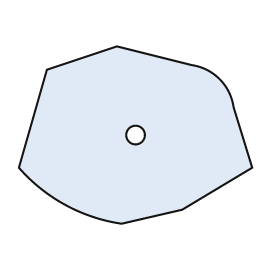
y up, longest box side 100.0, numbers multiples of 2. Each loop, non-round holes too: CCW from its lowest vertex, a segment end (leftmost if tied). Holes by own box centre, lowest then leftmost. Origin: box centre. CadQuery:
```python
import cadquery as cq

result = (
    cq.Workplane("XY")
    .moveTo(-6.0, -38.0)
    .lineTo(20.0, -32.0)
    .lineTo(50.0, -14.0)
    .lineTo(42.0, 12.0)
    .threePointArc((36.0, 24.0), (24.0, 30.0))
    .lineTo(-8.0, 38.0)
    .lineTo(-38.0, 28.0)
    .lineTo(-50.0, -14.0)
    .threePointArc((-30.0, -30.0), (-6.0, -38.0))
    .close()
    .moveTo(0.0, 0.0)
    .circle(4.0)
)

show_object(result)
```